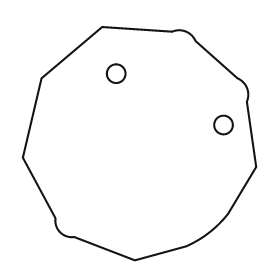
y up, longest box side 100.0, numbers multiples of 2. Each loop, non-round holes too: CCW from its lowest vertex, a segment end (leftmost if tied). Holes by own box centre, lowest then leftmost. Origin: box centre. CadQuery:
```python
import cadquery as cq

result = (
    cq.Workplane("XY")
    .moveTo(-2.0, -50.0)
    .lineTo(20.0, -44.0)
    .threePointArc((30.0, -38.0), (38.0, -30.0))
    .lineTo(50.0, -10.0)
    .lineTo(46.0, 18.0)
    .threePointArc((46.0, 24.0), (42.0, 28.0))
    .lineTo(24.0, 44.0)
    .threePointArc((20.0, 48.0), (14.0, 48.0))
    .lineTo(-16.0, 50.0)
    .lineTo(-42.0, 28.0)
    .lineTo(-50.0, -6.0)
    .lineTo(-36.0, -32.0)
    .threePointArc((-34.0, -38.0), (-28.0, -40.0))
    .close()
    .moveTo(36.0, 8.0)
    .circle(4.0)
    .moveTo(-10.0, 30.0)
    .circle(4.0)
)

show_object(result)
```